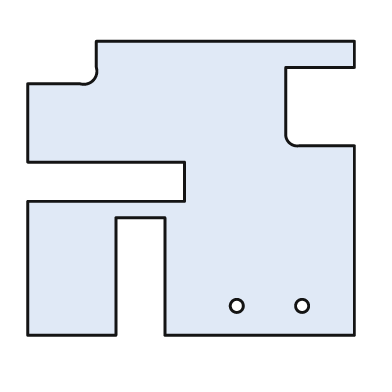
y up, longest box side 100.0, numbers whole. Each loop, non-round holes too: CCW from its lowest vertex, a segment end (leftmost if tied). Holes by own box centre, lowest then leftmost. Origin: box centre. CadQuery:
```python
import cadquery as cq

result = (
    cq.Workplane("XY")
    .moveTo(-50.0, -45.0)
    .lineTo(-23.0, -45.0)
    .lineTo(-23.0, -9.0)
    .lineTo(-8.0, -9.0)
    .lineTo(-8.0, -45.0)
    .lineTo(50.0, -45.0)
    .lineTo(50.0, 13.0)
    .lineTo(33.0, 13.0)
    .threePointArc((30.0, 14.0), (29.0, 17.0))
    .lineTo(29.0, 37.0)
    .lineTo(50.0, 37.0)
    .lineTo(50.0, 45.0)
    .lineTo(-29.0, 45.0)
    .lineTo(-29.0, 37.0)
    .threePointArc((-30.0, 33.0), (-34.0, 32.0))
    .lineTo(-50.0, 32.0)
    .lineTo(-50.0, 8.0)
    .lineTo(-2.0, 8.0)
    .lineTo(-2.0, -4.0)
    .lineTo(-50.0, -4.0)
    .close()
    .moveTo(14.0, -36.0)
    .circle(2.0)
    .moveTo(34.0, -36.0)
    .circle(2.0)
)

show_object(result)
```